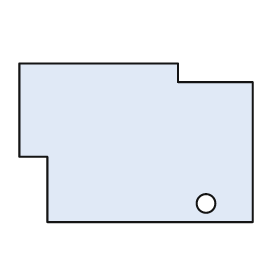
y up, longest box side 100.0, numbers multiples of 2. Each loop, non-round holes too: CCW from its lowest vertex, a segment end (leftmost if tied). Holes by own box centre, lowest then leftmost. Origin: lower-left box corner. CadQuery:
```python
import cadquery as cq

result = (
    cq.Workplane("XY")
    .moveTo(12.0, 0.0)
    .lineTo(100.0, 0.0)
    .lineTo(100.0, 60.0)
    .lineTo(68.0, 60.0)
    .lineTo(68.0, 68.0)
    .lineTo(0.0, 68.0)
    .lineTo(0.0, 28.0)
    .lineTo(12.0, 28.0)
    .close()
    .moveTo(80.0, 8.0)
    .circle(4.0)
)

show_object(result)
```